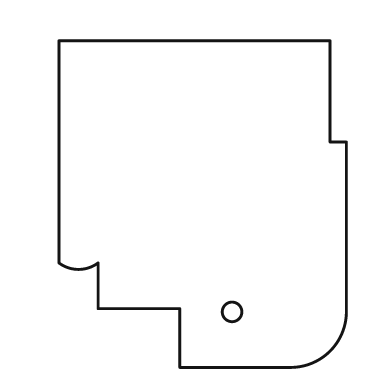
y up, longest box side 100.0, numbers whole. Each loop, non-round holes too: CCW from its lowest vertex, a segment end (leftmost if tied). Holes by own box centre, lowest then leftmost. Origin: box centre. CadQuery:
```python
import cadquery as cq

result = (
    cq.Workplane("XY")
    .moveTo(-7.0, -50.0)
    .lineTo(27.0, -50.0)
    .threePointArc((39.0, -45.0), (44.0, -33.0))
    .lineTo(44.0, 19.0)
    .lineTo(39.0, 19.0)
    .lineTo(39.0, 50.0)
    .lineTo(-44.0, 50.0)
    .lineTo(-44.0, -18.0)
    .threePointArc((-38.0, -20.0), (-32.0, -18.0))
    .lineTo(-32.0, -32.0)
    .lineTo(-7.0, -32.0)
    .close()
    .moveTo(9.0, -33.0)
    .circle(3.0)
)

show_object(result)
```